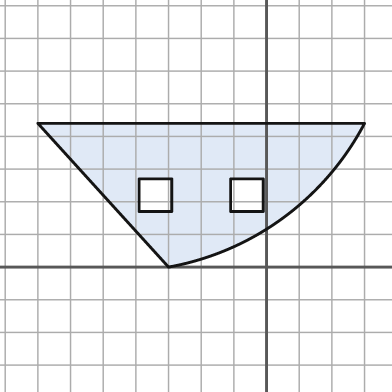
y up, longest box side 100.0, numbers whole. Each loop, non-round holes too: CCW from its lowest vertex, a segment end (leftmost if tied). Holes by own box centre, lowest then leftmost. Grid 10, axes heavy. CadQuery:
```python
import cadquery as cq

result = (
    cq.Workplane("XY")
    .moveTo(-30.0, 0.0)
    .threePointArc((5.0, 15.0), (30.0, 44.0))
    .lineTo(-70.0, 44.0)
    .close()
    .moveTo(-39.0, 17.0)
    .lineTo(-29.0, 17.0)
    .lineTo(-29.0, 27.0)
    .lineTo(-39.0, 27.0)
    .close()
    .moveTo(-11.0, 17.0)
    .lineTo(-1.0, 17.0)
    .lineTo(-1.0, 27.0)
    .lineTo(-11.0, 27.0)
    .close()
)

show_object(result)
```